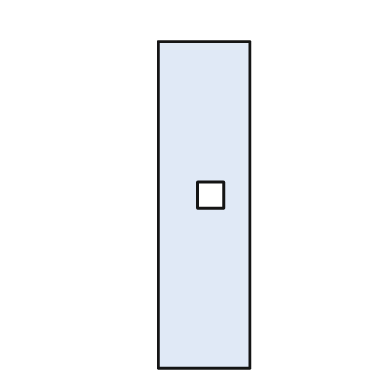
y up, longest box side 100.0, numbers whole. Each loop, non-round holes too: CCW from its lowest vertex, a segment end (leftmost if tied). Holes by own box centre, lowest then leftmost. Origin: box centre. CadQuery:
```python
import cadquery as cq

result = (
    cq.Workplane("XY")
    .moveTo(-14.0, -50.0)
    .lineTo(14.0, -50.0)
    .lineTo(14.0, 50.0)
    .lineTo(-14.0, 50.0)
    .close()
    .moveTo(-2.0, -1.0)
    .lineTo(6.0, -1.0)
    .lineTo(6.0, 7.0)
    .lineTo(-2.0, 7.0)
    .close()
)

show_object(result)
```